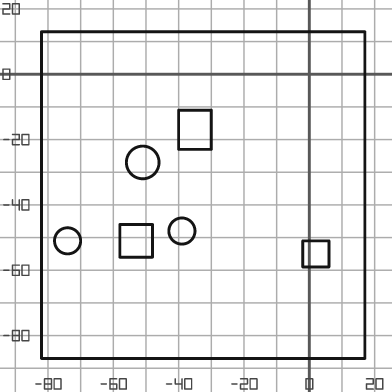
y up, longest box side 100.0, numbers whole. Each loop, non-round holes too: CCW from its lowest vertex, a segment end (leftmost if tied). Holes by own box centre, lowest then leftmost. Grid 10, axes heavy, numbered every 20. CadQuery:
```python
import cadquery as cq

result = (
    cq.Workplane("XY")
    .moveTo(-82.0, -87.0)
    .lineTo(17.0, -87.0)
    .lineTo(17.0, 13.0)
    .lineTo(-82.0, 13.0)
    .close()
    .moveTo(-2.0, -59.0)
    .lineTo(6.0, -59.0)
    .lineTo(6.0, -51.0)
    .lineTo(-2.0, -51.0)
    .close()
    .moveTo(-74.0, -51.0)
    .circle(4.0)
    .moveTo(-58.0, -56.0)
    .lineTo(-48.0, -56.0)
    .lineTo(-48.0, -46.0)
    .lineTo(-58.0, -46.0)
    .close()
    .moveTo(-39.0, -48.0)
    .circle(4.0)
    .moveTo(-51.0, -27.0)
    .circle(5.0)
    .moveTo(-40.0, -23.0)
    .lineTo(-30.0, -23.0)
    .lineTo(-30.0, -11.0)
    .lineTo(-40.0, -11.0)
    .close()
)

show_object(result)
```